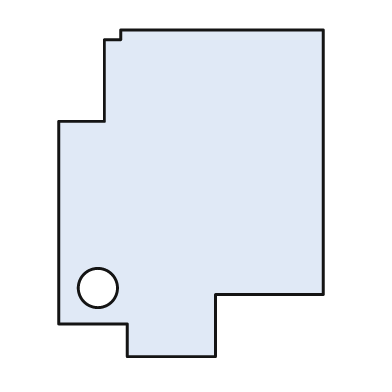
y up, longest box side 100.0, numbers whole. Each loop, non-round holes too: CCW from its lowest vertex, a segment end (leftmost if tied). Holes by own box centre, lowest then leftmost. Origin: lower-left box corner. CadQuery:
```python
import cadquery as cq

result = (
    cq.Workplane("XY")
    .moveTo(21.0, 0.0)
    .lineTo(48.0, 0.0)
    .lineTo(48.0, 19.0)
    .lineTo(81.0, 19.0)
    .lineTo(81.0, 100.0)
    .lineTo(19.0, 100.0)
    .lineTo(19.0, 97.0)
    .lineTo(14.0, 97.0)
    .lineTo(14.0, 72.0)
    .lineTo(0.0, 72.0)
    .lineTo(0.0, 10.0)
    .lineTo(21.0, 10.0)
    .close()
    .moveTo(12.0, 21.0)
    .circle(6.0)
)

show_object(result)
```